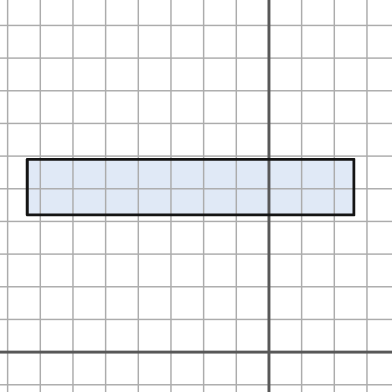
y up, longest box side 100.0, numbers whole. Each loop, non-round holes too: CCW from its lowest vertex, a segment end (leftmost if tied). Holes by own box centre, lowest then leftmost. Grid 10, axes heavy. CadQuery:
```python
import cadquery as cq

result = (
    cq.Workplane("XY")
    .moveTo(-74.0, 42.0)
    .lineTo(26.0, 42.0)
    .lineTo(26.0, 59.0)
    .lineTo(-74.0, 59.0)
    .close()
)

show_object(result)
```